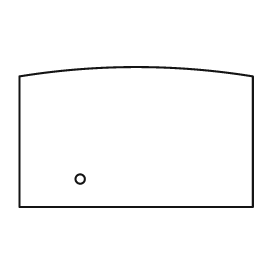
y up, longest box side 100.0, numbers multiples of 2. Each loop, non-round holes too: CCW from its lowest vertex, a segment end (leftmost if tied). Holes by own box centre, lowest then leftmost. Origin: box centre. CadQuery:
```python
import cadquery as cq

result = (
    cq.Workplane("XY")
    .moveTo(-50.0, -30.0)
    .lineTo(50.0, -30.0)
    .lineTo(50.0, 26.0)
    .threePointArc((0.0, 30.0), (-50.0, 26.0))
    .close()
    .moveTo(-24.0, -18.0)
    .circle(2.0)
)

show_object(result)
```